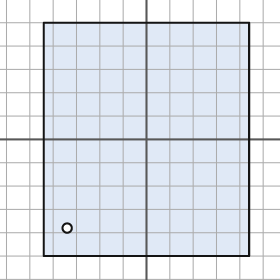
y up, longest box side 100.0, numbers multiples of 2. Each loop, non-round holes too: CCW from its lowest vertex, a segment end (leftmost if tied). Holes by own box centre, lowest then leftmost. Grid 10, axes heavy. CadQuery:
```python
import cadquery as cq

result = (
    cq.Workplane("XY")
    .moveTo(-44.0, -50.0)
    .lineTo(44.0, -50.0)
    .lineTo(44.0, 50.0)
    .lineTo(-44.0, 50.0)
    .close()
    .moveTo(-34.0, -38.0)
    .circle(2.0)
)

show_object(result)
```